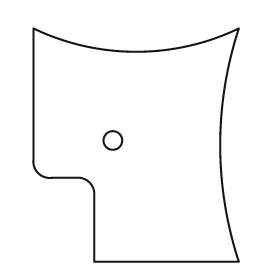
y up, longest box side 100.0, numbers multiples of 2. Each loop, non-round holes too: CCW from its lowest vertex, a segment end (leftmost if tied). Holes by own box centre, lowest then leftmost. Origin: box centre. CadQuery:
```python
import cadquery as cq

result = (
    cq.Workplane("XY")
    .moveTo(-18.0, -50.0)
    .lineTo(44.0, -50.0)
    .threePointArc((36.0, 0.0), (44.0, 50.0))
    .threePointArc((0.0, 40.0), (-44.0, 50.0))
    .lineTo(-44.0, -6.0)
    .threePointArc((-42.0, -12.0), (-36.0, -14.0))
    .lineTo(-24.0, -14.0)
    .threePointArc((-20.0, -16.0), (-18.0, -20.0))
    .close()
    .moveTo(-10.0, 2.0)
    .circle(4.0)
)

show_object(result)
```